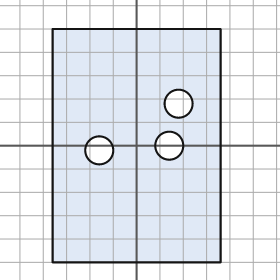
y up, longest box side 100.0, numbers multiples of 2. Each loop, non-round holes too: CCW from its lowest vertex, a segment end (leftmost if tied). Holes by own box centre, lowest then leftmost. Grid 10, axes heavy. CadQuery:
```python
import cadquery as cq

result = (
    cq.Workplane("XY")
    .moveTo(-36.0, -50.0)
    .lineTo(36.0, -50.0)
    .lineTo(36.0, 50.0)
    .lineTo(-36.0, 50.0)
    .close()
    .moveTo(-16.0, -2.0)
    .circle(6.0)
    .moveTo(14.0, 0.0)
    .circle(6.0)
    .moveTo(18.0, 18.0)
    .circle(6.0)
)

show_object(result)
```